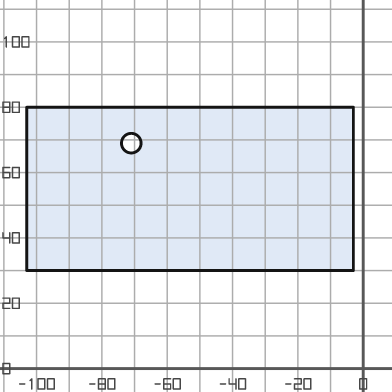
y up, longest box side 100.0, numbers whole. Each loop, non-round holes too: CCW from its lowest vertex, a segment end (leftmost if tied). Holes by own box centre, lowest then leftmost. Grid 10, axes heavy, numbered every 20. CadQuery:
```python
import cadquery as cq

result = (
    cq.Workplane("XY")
    .moveTo(-103.0, 30.0)
    .lineTo(-3.0, 30.0)
    .lineTo(-3.0, 80.0)
    .lineTo(-103.0, 80.0)
    .close()
    .moveTo(-71.0, 69.0)
    .circle(3.0)
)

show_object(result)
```